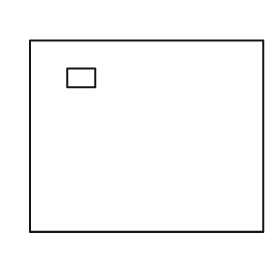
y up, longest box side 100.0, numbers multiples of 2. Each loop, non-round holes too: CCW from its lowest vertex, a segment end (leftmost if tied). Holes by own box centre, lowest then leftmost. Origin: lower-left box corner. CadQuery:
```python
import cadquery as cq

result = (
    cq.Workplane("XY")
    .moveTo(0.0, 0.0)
    .lineTo(100.0, 0.0)
    .lineTo(100.0, 82.0)
    .lineTo(0.0, 82.0)
    .close()
    .moveTo(16.0, 62.0)
    .lineTo(28.0, 62.0)
    .lineTo(28.0, 70.0)
    .lineTo(16.0, 70.0)
    .close()
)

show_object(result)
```